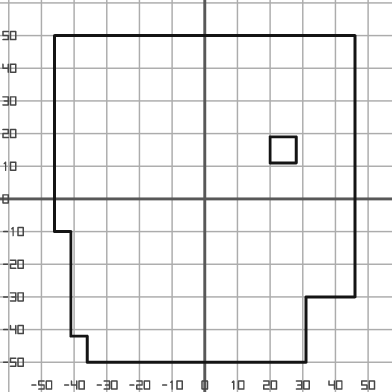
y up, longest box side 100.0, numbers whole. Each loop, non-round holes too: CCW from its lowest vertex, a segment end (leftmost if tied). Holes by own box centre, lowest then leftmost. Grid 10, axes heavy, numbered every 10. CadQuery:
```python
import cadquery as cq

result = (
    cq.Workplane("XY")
    .moveTo(-36.0, -50.0)
    .lineTo(31.0, -50.0)
    .lineTo(31.0, -30.0)
    .lineTo(46.0, -30.0)
    .lineTo(46.0, 50.0)
    .lineTo(-46.0, 50.0)
    .lineTo(-46.0, -10.0)
    .lineTo(-41.0, -10.0)
    .lineTo(-41.0, -42.0)
    .lineTo(-36.0, -42.0)
    .close()
    .moveTo(20.0, 11.0)
    .lineTo(28.0, 11.0)
    .lineTo(28.0, 19.0)
    .lineTo(20.0, 19.0)
    .close()
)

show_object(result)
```